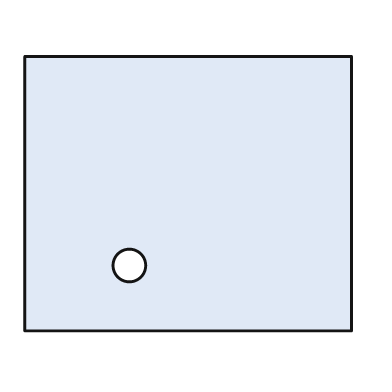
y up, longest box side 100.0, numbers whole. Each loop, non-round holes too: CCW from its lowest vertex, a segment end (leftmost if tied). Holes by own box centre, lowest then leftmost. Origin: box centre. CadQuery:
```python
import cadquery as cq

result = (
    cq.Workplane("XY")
    .moveTo(-50.0, -42.0)
    .lineTo(50.0, -42.0)
    .lineTo(50.0, 42.0)
    .lineTo(-50.0, 42.0)
    .close()
    .moveTo(-18.0, -22.0)
    .circle(5.0)
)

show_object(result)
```